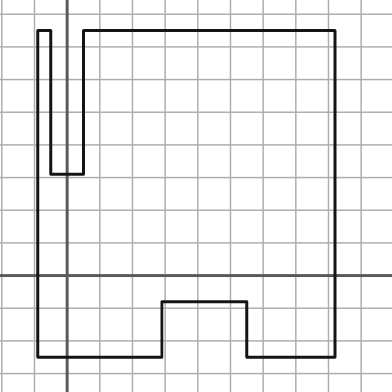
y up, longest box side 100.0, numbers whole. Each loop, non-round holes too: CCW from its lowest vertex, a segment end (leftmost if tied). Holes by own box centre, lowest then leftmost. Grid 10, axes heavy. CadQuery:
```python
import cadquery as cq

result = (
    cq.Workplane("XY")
    .moveTo(-9.0, -25.0)
    .lineTo(29.0, -25.0)
    .lineTo(29.0, -8.0)
    .lineTo(55.0, -8.0)
    .lineTo(55.0, -25.0)
    .lineTo(82.0, -25.0)
    .lineTo(82.0, 75.0)
    .lineTo(5.0, 75.0)
    .lineTo(5.0, 31.0)
    .lineTo(-5.0, 31.0)
    .lineTo(-5.0, 75.0)
    .lineTo(-9.0, 75.0)
    .close()
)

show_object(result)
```